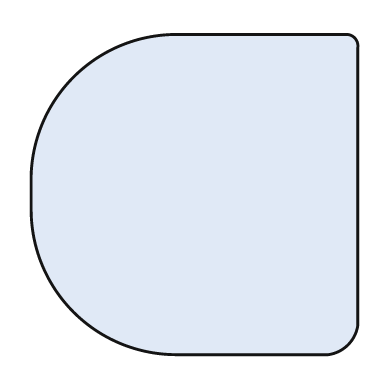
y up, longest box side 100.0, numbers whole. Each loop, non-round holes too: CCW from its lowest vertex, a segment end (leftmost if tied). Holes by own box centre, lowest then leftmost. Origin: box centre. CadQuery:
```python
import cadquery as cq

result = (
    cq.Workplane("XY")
    .moveTo(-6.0, -49.0)
    .lineTo(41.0, -49.0)
    .threePointArc((47.0, -46.0), (50.0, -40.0))
    .lineTo(50.0, 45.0)
    .threePointArc((49.0, 48.0), (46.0, 49.0))
    .lineTo(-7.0, 49.0)
    .threePointArc((-37.0, 36.0), (-50.0, 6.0))
    .lineTo(-50.0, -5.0)
    .threePointArc((-37.0, -36.0), (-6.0, -49.0))
    .close()
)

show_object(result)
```